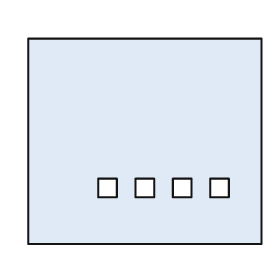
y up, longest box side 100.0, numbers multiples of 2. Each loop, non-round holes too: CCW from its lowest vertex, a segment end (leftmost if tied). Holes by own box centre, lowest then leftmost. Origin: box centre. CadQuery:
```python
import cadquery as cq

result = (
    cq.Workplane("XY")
    .moveTo(-50.0, -44.0)
    .lineTo(50.0, -44.0)
    .lineTo(50.0, 44.0)
    .lineTo(-50.0, 44.0)
    .close()
    .moveTo(-20.0, -24.0)
    .lineTo(-12.0, -24.0)
    .lineTo(-12.0, -16.0)
    .lineTo(-20.0, -16.0)
    .close()
    .moveTo(-4.0, -24.0)
    .lineTo(4.0, -24.0)
    .lineTo(4.0, -16.0)
    .lineTo(-4.0, -16.0)
    .close()
    .moveTo(12.0, -24.0)
    .lineTo(20.0, -24.0)
    .lineTo(20.0, -16.0)
    .lineTo(12.0, -16.0)
    .close()
    .moveTo(28.0, -24.0)
    .lineTo(36.0, -24.0)
    .lineTo(36.0, -16.0)
    .lineTo(28.0, -16.0)
    .close()
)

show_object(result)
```